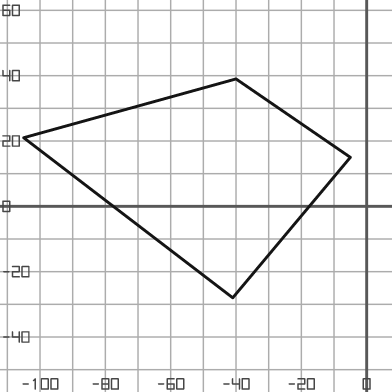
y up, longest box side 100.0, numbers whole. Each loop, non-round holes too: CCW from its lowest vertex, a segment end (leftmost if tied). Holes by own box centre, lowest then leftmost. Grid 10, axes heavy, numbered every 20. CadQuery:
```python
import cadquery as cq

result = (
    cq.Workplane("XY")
    .moveTo(-41.0, -28.0)
    .lineTo(-5.0, 15.0)
    .lineTo(-40.0, 39.0)
    .lineTo(-105.0, 21.0)
    .close()
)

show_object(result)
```